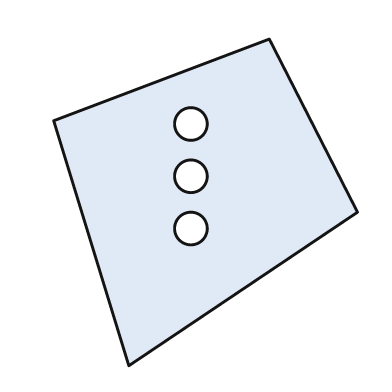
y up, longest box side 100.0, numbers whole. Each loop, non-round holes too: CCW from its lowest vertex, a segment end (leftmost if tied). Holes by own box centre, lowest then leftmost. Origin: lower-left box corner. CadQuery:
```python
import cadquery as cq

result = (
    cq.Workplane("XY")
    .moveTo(23.0, 0.0)
    .lineTo(93.0, 47.0)
    .lineTo(66.0, 100.0)
    .lineTo(0.0, 75.0)
    .close()
    .moveTo(42.0, 42.0)
    .circle(5.0)
    .moveTo(42.0, 58.0)
    .circle(5.0)
    .moveTo(42.0, 74.0)
    .circle(5.0)
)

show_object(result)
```